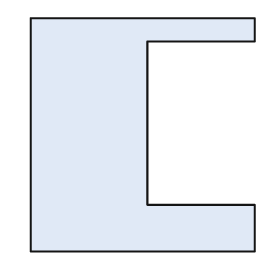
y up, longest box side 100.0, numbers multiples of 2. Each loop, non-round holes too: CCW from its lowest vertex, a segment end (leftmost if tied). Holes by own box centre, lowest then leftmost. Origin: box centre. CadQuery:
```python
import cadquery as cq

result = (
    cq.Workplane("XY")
    .moveTo(-48.0, -50.0)
    .lineTo(48.0, -50.0)
    .lineTo(48.0, -30.0)
    .lineTo(2.0, -30.0)
    .lineTo(2.0, 40.0)
    .lineTo(48.0, 40.0)
    .lineTo(48.0, 50.0)
    .lineTo(-48.0, 50.0)
    .close()
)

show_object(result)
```